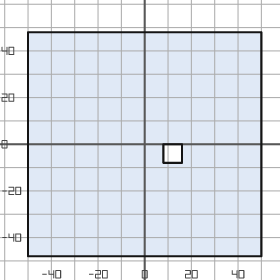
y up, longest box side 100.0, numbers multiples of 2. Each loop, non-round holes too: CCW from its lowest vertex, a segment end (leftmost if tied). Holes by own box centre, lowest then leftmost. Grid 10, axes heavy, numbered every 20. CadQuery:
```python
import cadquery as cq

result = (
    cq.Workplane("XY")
    .moveTo(-50.0, -48.0)
    .lineTo(50.0, -48.0)
    .lineTo(50.0, 48.0)
    .lineTo(-50.0, 48.0)
    .close()
    .moveTo(8.0, -8.0)
    .lineTo(16.0, -8.0)
    .lineTo(16.0, 0.0)
    .lineTo(8.0, 0.0)
    .close()
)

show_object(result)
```